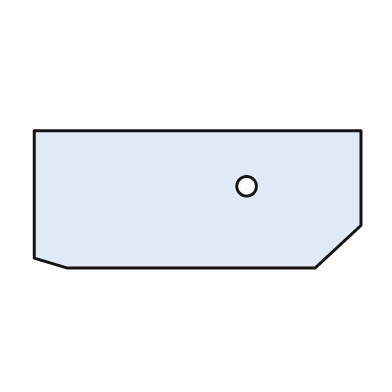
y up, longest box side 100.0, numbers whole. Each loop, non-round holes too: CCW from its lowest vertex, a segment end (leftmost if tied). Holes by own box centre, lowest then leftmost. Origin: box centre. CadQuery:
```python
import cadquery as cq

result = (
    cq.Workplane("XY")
    .moveTo(-40.0, -21.0)
    .lineTo(36.0, -21.0)
    .lineTo(50.0, -8.0)
    .lineTo(50.0, 21.0)
    .lineTo(-50.0, 21.0)
    .lineTo(-50.0, -18.0)
    .close()
    .moveTo(15.0, 4.0)
    .circle(3.0)
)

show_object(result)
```